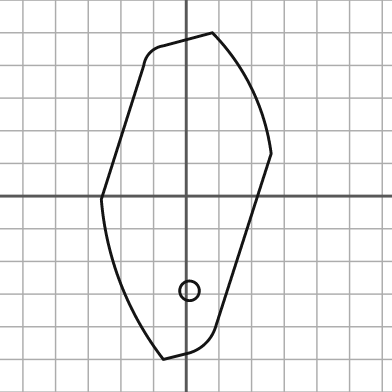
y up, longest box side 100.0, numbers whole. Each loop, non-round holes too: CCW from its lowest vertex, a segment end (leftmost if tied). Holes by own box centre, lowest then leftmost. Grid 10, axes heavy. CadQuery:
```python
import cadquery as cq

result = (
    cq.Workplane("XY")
    .moveTo(-7.0, -50.0)
    .lineTo(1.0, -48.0)
    .threePointArc((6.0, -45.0), (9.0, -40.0))
    .lineTo(26.0, 13.0)
    .threePointArc((20.0, 33.0), (8.0, 50.0))
    .lineTo(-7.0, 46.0)
    .threePointArc((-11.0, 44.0), (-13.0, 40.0))
    .lineTo(-26.0, -1.0)
    .threePointArc((-20.0, -27.0), (-7.0, -50.0))
    .close()
    .moveTo(1.0, -29.0)
    .circle(3.0)
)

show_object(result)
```